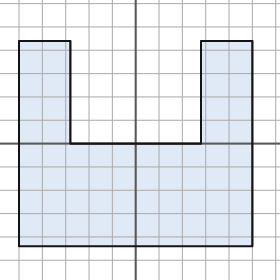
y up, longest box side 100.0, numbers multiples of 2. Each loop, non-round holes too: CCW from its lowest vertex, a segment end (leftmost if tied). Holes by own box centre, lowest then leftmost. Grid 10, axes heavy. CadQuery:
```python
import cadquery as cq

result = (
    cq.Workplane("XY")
    .moveTo(-50.0, -44.0)
    .lineTo(50.0, -44.0)
    .lineTo(50.0, 44.0)
    .lineTo(28.0, 44.0)
    .lineTo(28.0, 0.0)
    .lineTo(-28.0, 0.0)
    .lineTo(-28.0, 44.0)
    .lineTo(-50.0, 44.0)
    .close()
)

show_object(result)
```